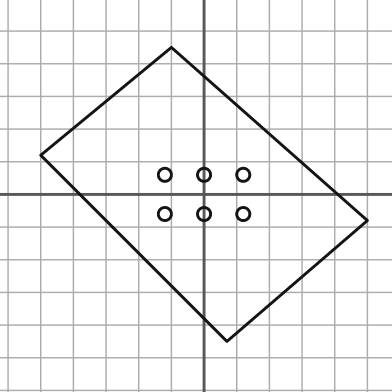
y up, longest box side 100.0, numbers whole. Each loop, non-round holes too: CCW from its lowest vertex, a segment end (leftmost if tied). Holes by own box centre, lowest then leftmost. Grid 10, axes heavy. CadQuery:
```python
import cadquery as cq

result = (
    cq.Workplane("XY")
    .moveTo(7.0, -45.0)
    .lineTo(50.0, -8.0)
    .lineTo(-10.0, 45.0)
    .lineTo(-50.0, 12.0)
    .close()
    .moveTo(-12.0, -6.0)
    .circle(2.0)
    .moveTo(0.0, -6.0)
    .circle(2.0)
    .moveTo(12.0, -6.0)
    .circle(2.0)
    .moveTo(-12.0, 6.0)
    .circle(2.0)
    .moveTo(0.0, 6.0)
    .circle(2.0)
    .moveTo(12.0, 6.0)
    .circle(2.0)
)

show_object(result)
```